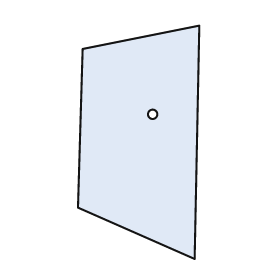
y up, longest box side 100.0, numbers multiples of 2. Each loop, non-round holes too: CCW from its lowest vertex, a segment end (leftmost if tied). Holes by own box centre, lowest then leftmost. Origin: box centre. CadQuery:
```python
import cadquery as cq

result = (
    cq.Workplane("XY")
    .moveTo(24.0, -50.0)
    .lineTo(26.0, 50.0)
    .lineTo(-24.0, 40.0)
    .lineTo(-26.0, -28.0)
    .close()
    .moveTo(6.0, 12.0)
    .circle(2.0)
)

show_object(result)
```